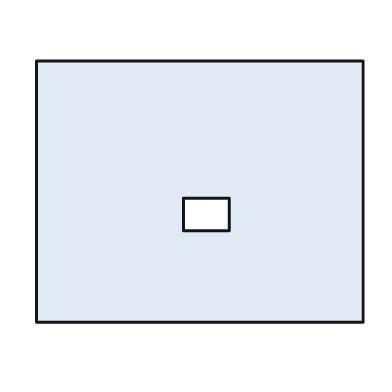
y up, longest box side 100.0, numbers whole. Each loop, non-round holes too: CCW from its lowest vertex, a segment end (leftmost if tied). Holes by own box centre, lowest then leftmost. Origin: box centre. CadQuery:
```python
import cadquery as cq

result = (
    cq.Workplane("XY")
    .moveTo(-50.0, -40.0)
    .lineTo(50.0, -40.0)
    .lineTo(50.0, 40.0)
    .lineTo(-50.0, 40.0)
    .close()
    .moveTo(-5.0, -12.0)
    .lineTo(9.0, -12.0)
    .lineTo(9.0, -2.0)
    .lineTo(-5.0, -2.0)
    .close()
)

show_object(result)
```